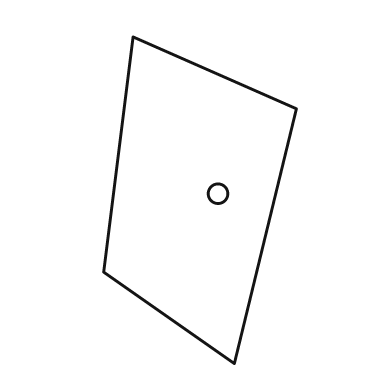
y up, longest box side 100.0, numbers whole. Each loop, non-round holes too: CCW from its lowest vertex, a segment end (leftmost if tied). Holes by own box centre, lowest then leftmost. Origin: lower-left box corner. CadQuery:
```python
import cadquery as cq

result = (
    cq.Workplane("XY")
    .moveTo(40.0, 0.0)
    .lineTo(59.0, 78.0)
    .lineTo(9.0, 100.0)
    .lineTo(0.0, 28.0)
    .close()
    .moveTo(35.0, 52.0)
    .circle(3.0)
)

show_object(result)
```